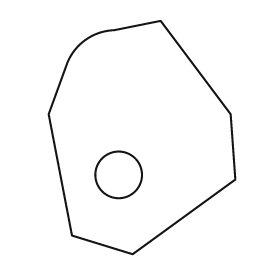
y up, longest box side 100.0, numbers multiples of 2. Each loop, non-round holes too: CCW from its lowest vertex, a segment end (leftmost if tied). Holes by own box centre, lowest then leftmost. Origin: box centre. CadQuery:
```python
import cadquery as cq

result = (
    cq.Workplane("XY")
    .moveTo(-4.0, -50.0)
    .lineTo(40.0, -18.0)
    .lineTo(38.0, 10.0)
    .lineTo(8.0, 50.0)
    .lineTo(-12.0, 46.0)
    .threePointArc((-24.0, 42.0), (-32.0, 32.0))
    .lineTo(-40.0, 10.0)
    .lineTo(-30.0, -42.0)
    .close()
    .moveTo(-10.0, -16.0)
    .circle(10.0)
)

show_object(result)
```